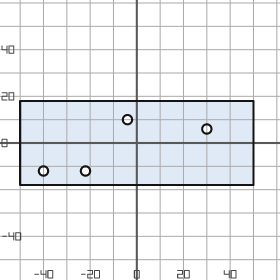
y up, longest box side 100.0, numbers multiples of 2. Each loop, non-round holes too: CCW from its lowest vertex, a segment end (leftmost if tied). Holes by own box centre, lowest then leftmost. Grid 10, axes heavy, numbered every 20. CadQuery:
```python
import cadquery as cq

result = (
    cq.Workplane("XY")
    .moveTo(-50.0, -18.0)
    .lineTo(50.0, -18.0)
    .lineTo(50.0, 18.0)
    .lineTo(-50.0, 18.0)
    .close()
    .moveTo(-40.0, -12.0)
    .circle(2.0)
    .moveTo(-22.0, -12.0)
    .circle(2.0)
    .moveTo(30.0, 6.0)
    .circle(2.0)
    .moveTo(-4.0, 10.0)
    .circle(2.0)
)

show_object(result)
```